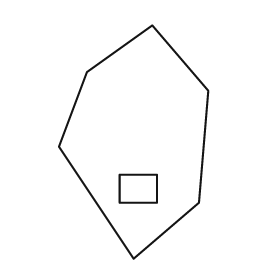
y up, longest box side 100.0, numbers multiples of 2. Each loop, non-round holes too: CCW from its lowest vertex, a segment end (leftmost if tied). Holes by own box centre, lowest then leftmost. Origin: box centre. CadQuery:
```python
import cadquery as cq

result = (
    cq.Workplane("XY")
    .moveTo(0.0, -50.0)
    .lineTo(28.0, -26.0)
    .lineTo(32.0, 22.0)
    .lineTo(8.0, 50.0)
    .lineTo(-20.0, 30.0)
    .lineTo(-32.0, -2.0)
    .close()
    .moveTo(-6.0, -26.0)
    .lineTo(10.0, -26.0)
    .lineTo(10.0, -14.0)
    .lineTo(-6.0, -14.0)
    .close()
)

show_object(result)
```